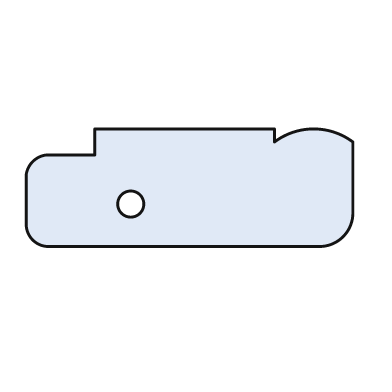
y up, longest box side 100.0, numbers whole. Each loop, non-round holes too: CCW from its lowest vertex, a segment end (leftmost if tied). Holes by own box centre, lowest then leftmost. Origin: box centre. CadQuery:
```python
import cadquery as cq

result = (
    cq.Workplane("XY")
    .moveTo(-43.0, -18.0)
    .lineTo(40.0, -18.0)
    .threePointArc((47.0, -15.0), (50.0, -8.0))
    .lineTo(50.0, 14.0)
    .threePointArc((38.0, 18.0), (26.0, 14.0))
    .lineTo(26.0, 18.0)
    .lineTo(-29.0, 18.0)
    .lineTo(-29.0, 10.0)
    .lineTo(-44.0, 10.0)
    .threePointArc((-48.0, 8.0), (-50.0, 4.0))
    .lineTo(-50.0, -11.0)
    .threePointArc((-48.0, -16.0), (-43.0, -18.0))
    .close()
    .moveTo(-18.0, -5.0)
    .circle(4.0)
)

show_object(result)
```